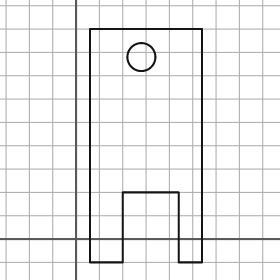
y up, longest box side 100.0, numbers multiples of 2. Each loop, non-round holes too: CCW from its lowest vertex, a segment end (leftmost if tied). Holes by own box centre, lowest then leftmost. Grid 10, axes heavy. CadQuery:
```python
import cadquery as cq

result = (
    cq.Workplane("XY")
    .moveTo(6.0, -10.0)
    .lineTo(20.0, -10.0)
    .lineTo(20.0, 20.0)
    .lineTo(44.0, 20.0)
    .lineTo(44.0, -10.0)
    .lineTo(54.0, -10.0)
    .lineTo(54.0, 90.0)
    .lineTo(6.0, 90.0)
    .close()
    .moveTo(28.0, 78.0)
    .circle(6.0)
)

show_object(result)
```